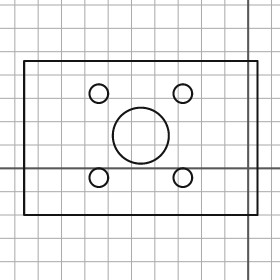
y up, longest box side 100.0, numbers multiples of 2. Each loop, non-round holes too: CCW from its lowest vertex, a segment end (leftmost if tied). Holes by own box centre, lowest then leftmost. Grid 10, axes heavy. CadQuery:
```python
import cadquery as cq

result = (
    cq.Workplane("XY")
    .moveTo(-96.0, -20.0)
    .lineTo(4.0, -20.0)
    .lineTo(4.0, 46.0)
    .lineTo(-96.0, 46.0)
    .close()
    .moveTo(-64.0, -4.0)
    .circle(4.0)
    .moveTo(-28.0, -4.0)
    .circle(4.0)
    .moveTo(-46.0, 14.0)
    .circle(12.0)
    .moveTo(-64.0, 32.0)
    .circle(4.0)
    .moveTo(-28.0, 32.0)
    .circle(4.0)
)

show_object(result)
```